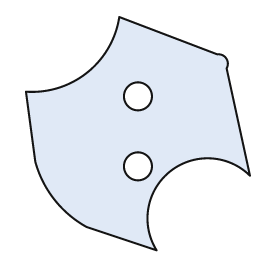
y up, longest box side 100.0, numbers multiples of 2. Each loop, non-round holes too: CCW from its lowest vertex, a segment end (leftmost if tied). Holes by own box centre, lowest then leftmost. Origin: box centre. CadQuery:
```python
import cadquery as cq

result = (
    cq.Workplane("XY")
    .moveTo(8.0, -50.0)
    .threePointArc((14.0, -16.0), (48.0, -18.0))
    .lineTo(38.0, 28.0)
    .threePointArc((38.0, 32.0), (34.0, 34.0))
    .lineTo(-8.0, 50.0)
    .threePointArc((-22.0, 26.0), (-48.0, 18.0))
    .lineTo(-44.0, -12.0)
    .threePointArc((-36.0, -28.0), (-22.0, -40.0))
    .close()
    .moveTo(0.0, -14.0)
    .circle(6.0)
    .moveTo(0.0, 16.0)
    .circle(6.0)
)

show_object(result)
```